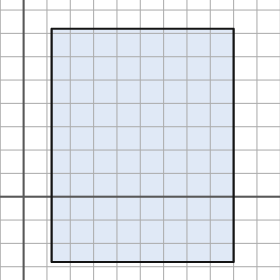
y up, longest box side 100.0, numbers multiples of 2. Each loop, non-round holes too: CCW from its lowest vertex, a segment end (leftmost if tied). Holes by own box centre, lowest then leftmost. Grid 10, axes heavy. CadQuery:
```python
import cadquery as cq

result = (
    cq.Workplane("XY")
    .moveTo(12.0, -28.0)
    .lineTo(90.0, -28.0)
    .lineTo(90.0, 72.0)
    .lineTo(12.0, 72.0)
    .close()
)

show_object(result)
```